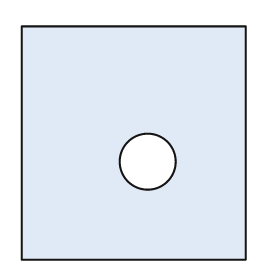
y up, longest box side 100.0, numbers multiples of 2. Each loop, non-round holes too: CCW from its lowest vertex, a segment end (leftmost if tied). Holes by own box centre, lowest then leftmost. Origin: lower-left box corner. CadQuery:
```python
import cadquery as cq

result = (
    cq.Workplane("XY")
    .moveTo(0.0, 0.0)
    .lineTo(96.0, 0.0)
    .lineTo(96.0, 100.0)
    .lineTo(0.0, 100.0)
    .close()
    .moveTo(54.0, 42.0)
    .circle(12.0)
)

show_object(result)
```